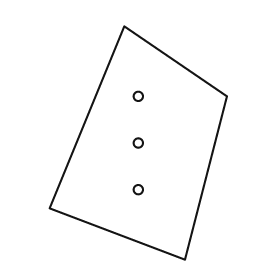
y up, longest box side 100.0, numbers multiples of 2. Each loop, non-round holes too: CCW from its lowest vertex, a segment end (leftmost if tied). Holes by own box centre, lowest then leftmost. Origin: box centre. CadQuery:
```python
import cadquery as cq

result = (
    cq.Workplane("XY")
    .moveTo(20.0, -50.0)
    .lineTo(38.0, 20.0)
    .lineTo(-6.0, 50.0)
    .lineTo(-38.0, -28.0)
    .close()
    .moveTo(0.0, -20.0)
    .circle(2.0)
    .moveTo(0.0, 0.0)
    .circle(2.0)
    .moveTo(0.0, 20.0)
    .circle(2.0)
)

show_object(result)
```